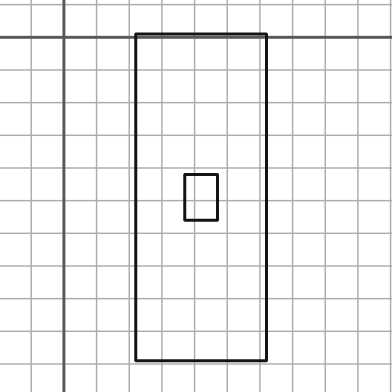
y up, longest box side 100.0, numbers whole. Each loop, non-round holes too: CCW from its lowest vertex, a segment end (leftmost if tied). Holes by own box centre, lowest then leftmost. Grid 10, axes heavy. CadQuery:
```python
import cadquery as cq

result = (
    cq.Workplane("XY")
    .moveTo(22.0, -99.0)
    .lineTo(62.0, -99.0)
    .lineTo(62.0, 1.0)
    .lineTo(22.0, 1.0)
    .close()
    .moveTo(37.0, -56.0)
    .lineTo(47.0, -56.0)
    .lineTo(47.0, -42.0)
    .lineTo(37.0, -42.0)
    .close()
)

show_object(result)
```